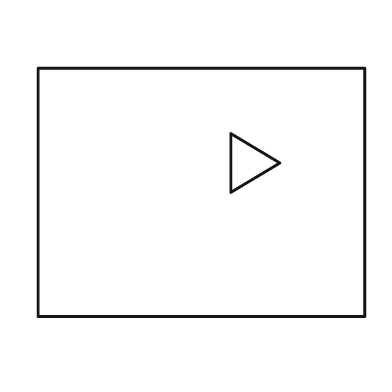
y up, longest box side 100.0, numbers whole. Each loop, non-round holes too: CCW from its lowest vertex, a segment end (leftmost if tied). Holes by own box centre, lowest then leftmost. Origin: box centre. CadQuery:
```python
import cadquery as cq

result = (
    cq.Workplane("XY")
    .moveTo(-50.0, -38.0)
    .lineTo(50.0, -38.0)
    .lineTo(50.0, 38.0)
    .lineTo(-50.0, 38.0)
    .close()
    .moveTo(9.0, 0.0)
    .lineTo(24.0, 9.0)
    .lineTo(9.0, 18.0)
    .close()
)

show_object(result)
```